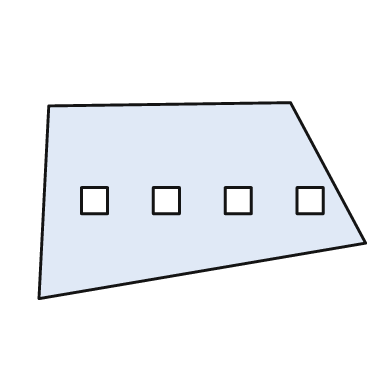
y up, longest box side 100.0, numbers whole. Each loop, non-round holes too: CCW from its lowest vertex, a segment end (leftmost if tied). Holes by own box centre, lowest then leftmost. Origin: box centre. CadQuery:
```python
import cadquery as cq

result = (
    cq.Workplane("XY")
    .moveTo(-50.0, -30.0)
    .lineTo(50.0, -13.0)
    .lineTo(27.0, 30.0)
    .lineTo(-47.0, 29.0)
    .close()
    .moveTo(-37.0, -4.0)
    .lineTo(-29.0, -4.0)
    .lineTo(-29.0, 4.0)
    .lineTo(-37.0, 4.0)
    .close()
    .moveTo(-15.0, -4.0)
    .lineTo(-7.0, -4.0)
    .lineTo(-7.0, 4.0)
    .lineTo(-15.0, 4.0)
    .close()
    .moveTo(7.0, -4.0)
    .lineTo(15.0, -4.0)
    .lineTo(15.0, 4.0)
    .lineTo(7.0, 4.0)
    .close()
    .moveTo(29.0, -4.0)
    .lineTo(37.0, -4.0)
    .lineTo(37.0, 4.0)
    .lineTo(29.0, 4.0)
    .close()
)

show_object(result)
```